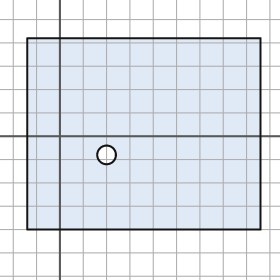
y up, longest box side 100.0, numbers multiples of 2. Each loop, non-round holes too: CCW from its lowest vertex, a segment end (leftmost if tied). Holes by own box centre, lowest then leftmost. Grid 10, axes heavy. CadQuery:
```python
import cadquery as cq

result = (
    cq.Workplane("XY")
    .moveTo(-14.0, -40.0)
    .lineTo(86.0, -40.0)
    .lineTo(86.0, 42.0)
    .lineTo(-14.0, 42.0)
    .close()
    .moveTo(20.0, -8.0)
    .circle(4.0)
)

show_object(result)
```